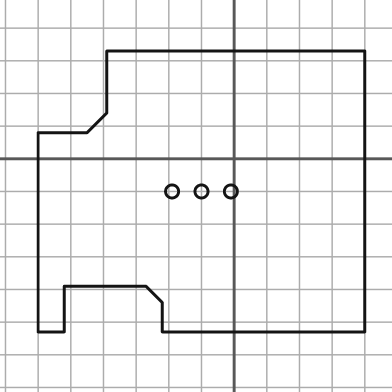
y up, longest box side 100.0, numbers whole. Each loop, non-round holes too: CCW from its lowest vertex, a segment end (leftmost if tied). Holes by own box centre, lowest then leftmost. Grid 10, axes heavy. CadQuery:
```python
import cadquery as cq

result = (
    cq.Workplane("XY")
    .moveTo(-60.0, -53.0)
    .lineTo(-52.0, -53.0)
    .lineTo(-52.0, -39.0)
    .lineTo(-27.0, -39.0)
    .lineTo(-22.0, -44.0)
    .lineTo(-22.0, -53.0)
    .lineTo(40.0, -53.0)
    .lineTo(40.0, 33.0)
    .lineTo(-39.0, 33.0)
    .lineTo(-39.0, 14.0)
    .lineTo(-45.0, 8.0)
    .lineTo(-60.0, 8.0)
    .close()
    .moveTo(-19.0, -10.0)
    .circle(2.0)
    .moveTo(-10.0, -10.0)
    .circle(2.0)
    .moveTo(-1.0, -10.0)
    .circle(2.0)
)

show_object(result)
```